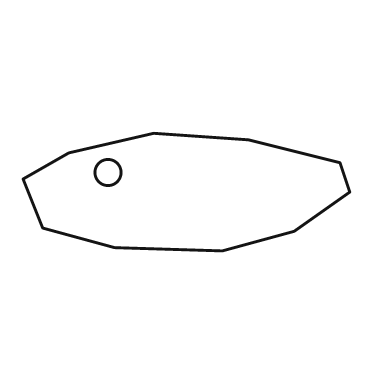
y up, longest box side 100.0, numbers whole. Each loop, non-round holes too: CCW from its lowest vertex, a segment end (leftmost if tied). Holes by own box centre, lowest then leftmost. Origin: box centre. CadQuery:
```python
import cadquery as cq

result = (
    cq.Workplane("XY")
    .moveTo(11.0, -18.0)
    .lineTo(33.0, -12.0)
    .lineTo(50.0, 0.0)
    .lineTo(47.0, 9.0)
    .lineTo(19.0, 16.0)
    .lineTo(-10.0, 18.0)
    .lineTo(-36.0, 12.0)
    .lineTo(-50.0, 4.0)
    .lineTo(-44.0, -11.0)
    .lineTo(-22.0, -17.0)
    .close()
    .moveTo(-24.0, 6.0)
    .circle(4.0)
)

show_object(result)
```